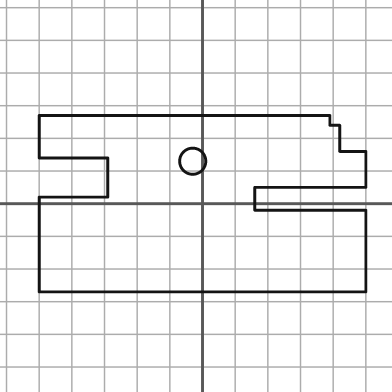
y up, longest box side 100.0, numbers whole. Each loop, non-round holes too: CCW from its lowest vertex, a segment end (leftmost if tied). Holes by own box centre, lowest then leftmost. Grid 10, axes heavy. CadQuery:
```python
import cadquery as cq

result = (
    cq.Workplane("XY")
    .moveTo(-50.0, -27.0)
    .lineTo(50.0, -27.0)
    .lineTo(50.0, -2.0)
    .lineTo(16.0, -2.0)
    .lineTo(16.0, 5.0)
    .lineTo(50.0, 5.0)
    .lineTo(50.0, 16.0)
    .lineTo(42.0, 16.0)
    .lineTo(42.0, 24.0)
    .lineTo(39.0, 24.0)
    .lineTo(39.0, 27.0)
    .lineTo(-50.0, 27.0)
    .lineTo(-50.0, 14.0)
    .lineTo(-29.0, 14.0)
    .lineTo(-29.0, 2.0)
    .lineTo(-50.0, 2.0)
    .close()
    .moveTo(-3.0, 13.0)
    .circle(4.0)
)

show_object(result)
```